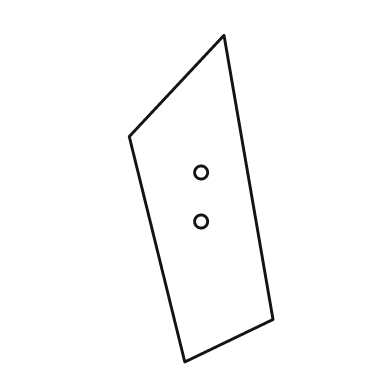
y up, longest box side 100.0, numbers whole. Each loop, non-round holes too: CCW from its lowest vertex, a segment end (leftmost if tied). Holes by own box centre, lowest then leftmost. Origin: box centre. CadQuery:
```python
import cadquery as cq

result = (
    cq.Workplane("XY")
    .moveTo(-5.0, -50.0)
    .lineTo(22.0, -37.0)
    .lineTo(7.0, 50.0)
    .lineTo(-22.0, 19.0)
    .close()
    .moveTo(0.0, -7.0)
    .circle(2.0)
    .moveTo(0.0, 8.0)
    .circle(2.0)
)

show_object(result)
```